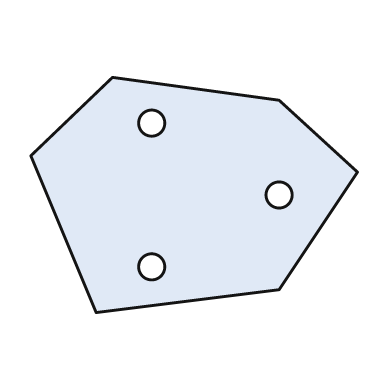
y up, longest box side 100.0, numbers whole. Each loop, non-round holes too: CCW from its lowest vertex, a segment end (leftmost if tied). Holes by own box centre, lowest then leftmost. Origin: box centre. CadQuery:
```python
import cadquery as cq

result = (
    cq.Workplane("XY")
    .moveTo(-30.0, -36.0)
    .lineTo(26.0, -29.0)
    .lineTo(50.0, 7.0)
    .lineTo(26.0, 29.0)
    .lineTo(-25.0, 36.0)
    .lineTo(-50.0, 12.0)
    .close()
    .moveTo(-13.0, -22.0)
    .circle(4.0)
    .moveTo(26.0, 0.0)
    .circle(4.0)
    .moveTo(-13.0, 22.0)
    .circle(4.0)
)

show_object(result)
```